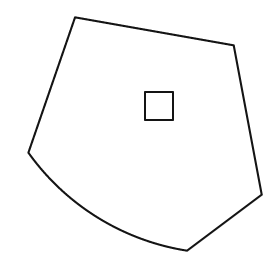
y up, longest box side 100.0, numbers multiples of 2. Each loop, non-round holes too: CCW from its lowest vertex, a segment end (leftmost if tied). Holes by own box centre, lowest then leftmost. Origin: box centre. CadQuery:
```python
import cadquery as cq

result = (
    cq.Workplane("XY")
    .moveTo(18.0, -50.0)
    .lineTo(50.0, -26.0)
    .lineTo(38.0, 38.0)
    .lineTo(-30.0, 50.0)
    .lineTo(-50.0, -8.0)
    .threePointArc((-20.0, -36.0), (18.0, -50.0))
    .close()
    .moveTo(0.0, 6.0)
    .lineTo(12.0, 6.0)
    .lineTo(12.0, 18.0)
    .lineTo(0.0, 18.0)
    .close()
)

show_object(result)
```